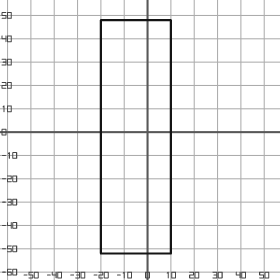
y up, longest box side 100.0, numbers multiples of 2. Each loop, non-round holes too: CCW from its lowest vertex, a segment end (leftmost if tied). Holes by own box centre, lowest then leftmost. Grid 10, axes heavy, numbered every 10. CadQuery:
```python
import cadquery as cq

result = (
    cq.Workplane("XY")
    .moveTo(-20.0, -52.0)
    .lineTo(10.0, -52.0)
    .lineTo(10.0, 48.0)
    .lineTo(-20.0, 48.0)
    .close()
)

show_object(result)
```